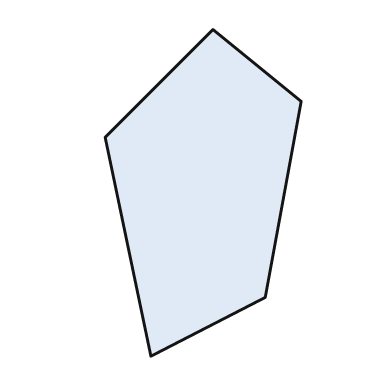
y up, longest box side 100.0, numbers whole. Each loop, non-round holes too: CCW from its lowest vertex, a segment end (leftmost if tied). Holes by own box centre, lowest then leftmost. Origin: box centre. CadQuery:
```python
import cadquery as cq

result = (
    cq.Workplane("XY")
    .moveTo(-16.0, -50.0)
    .lineTo(19.0, -32.0)
    .lineTo(30.0, 28.0)
    .lineTo(3.0, 50.0)
    .lineTo(-30.0, 17.0)
    .close()
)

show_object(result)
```